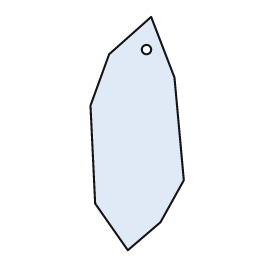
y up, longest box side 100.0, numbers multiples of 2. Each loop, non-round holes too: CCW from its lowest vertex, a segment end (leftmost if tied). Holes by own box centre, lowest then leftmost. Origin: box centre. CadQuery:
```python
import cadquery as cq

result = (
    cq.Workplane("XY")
    .moveTo(-4.0, -50.0)
    .lineTo(10.0, -38.0)
    .lineTo(20.0, -20.0)
    .lineTo(16.0, 24.0)
    .lineTo(6.0, 50.0)
    .lineTo(-12.0, 34.0)
    .lineTo(-20.0, 12.0)
    .lineTo(-18.0, -30.0)
    .close()
    .moveTo(4.0, 36.0)
    .circle(2.0)
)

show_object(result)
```